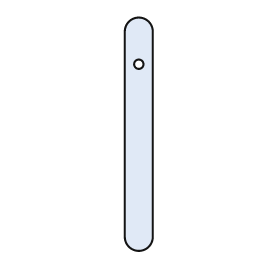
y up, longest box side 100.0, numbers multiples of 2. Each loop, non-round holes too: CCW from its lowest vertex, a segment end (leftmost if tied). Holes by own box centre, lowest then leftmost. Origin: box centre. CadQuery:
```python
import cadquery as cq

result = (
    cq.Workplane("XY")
    .moveTo(-6.0, -44.0)
    .threePointArc((0.0, -50.0), (6.0, -44.0))
    .lineTo(6.0, 44.0)
    .threePointArc((0.0, 50.0), (-6.0, 44.0))
    .close()
    .moveTo(0.0, 30.0)
    .circle(2.0)
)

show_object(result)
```